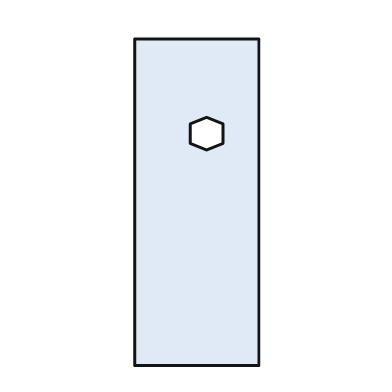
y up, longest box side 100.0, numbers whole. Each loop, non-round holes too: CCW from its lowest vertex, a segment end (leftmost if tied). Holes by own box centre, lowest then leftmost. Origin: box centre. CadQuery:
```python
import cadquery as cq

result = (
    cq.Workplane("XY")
    .moveTo(-19.0, -50.0)
    .lineTo(19.0, -50.0)
    .lineTo(19.0, 50.0)
    .lineTo(-19.0, 50.0)
    .close()
    .moveTo(3.0, 16.0)
    .lineTo(8.0, 18.0)
    .lineTo(8.0, 24.0)
    .lineTo(3.0, 26.0)
    .lineTo(-2.0, 24.0)
    .lineTo(-2.0, 18.0)
    .close()
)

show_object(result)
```